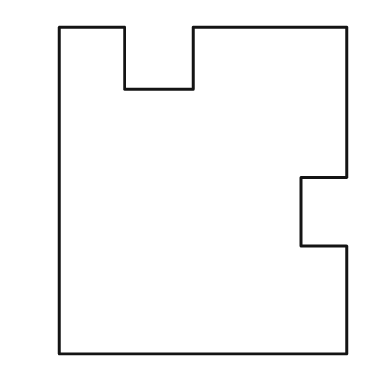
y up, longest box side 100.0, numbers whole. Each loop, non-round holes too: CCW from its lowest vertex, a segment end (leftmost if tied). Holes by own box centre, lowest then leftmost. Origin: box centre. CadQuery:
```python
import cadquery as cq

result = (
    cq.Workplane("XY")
    .moveTo(-44.0, -50.0)
    .lineTo(44.0, -50.0)
    .lineTo(44.0, -17.0)
    .lineTo(30.0, -17.0)
    .lineTo(30.0, 4.0)
    .lineTo(44.0, 4.0)
    .lineTo(44.0, 50.0)
    .lineTo(-3.0, 50.0)
    .lineTo(-3.0, 31.0)
    .lineTo(-24.0, 31.0)
    .lineTo(-24.0, 50.0)
    .lineTo(-44.0, 50.0)
    .close()
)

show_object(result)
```